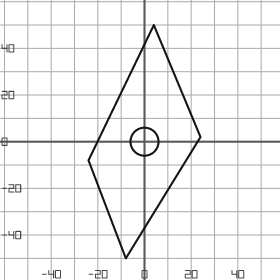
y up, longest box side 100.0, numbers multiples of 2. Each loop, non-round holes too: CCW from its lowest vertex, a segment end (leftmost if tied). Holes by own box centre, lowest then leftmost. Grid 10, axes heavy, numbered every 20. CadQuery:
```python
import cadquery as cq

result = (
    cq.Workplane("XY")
    .moveTo(-8.0, -50.0)
    .lineTo(24.0, 2.0)
    .lineTo(4.0, 50.0)
    .lineTo(-24.0, -8.0)
    .close()
    .moveTo(0.0, 0.0)
    .circle(6.0)
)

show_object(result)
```